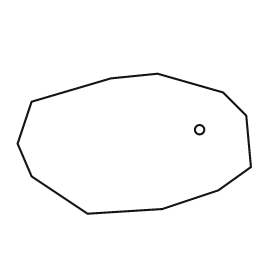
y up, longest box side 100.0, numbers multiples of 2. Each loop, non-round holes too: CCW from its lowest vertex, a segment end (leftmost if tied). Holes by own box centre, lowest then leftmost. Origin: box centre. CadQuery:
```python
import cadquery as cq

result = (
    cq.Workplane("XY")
    .moveTo(-20.0, -30.0)
    .lineTo(12.0, -28.0)
    .lineTo(36.0, -20.0)
    .lineTo(50.0, -10.0)
    .lineTo(48.0, 12.0)
    .lineTo(38.0, 22.0)
    .lineTo(10.0, 30.0)
    .lineTo(-10.0, 28.0)
    .lineTo(-44.0, 18.0)
    .lineTo(-50.0, 0.0)
    .lineTo(-44.0, -14.0)
    .close()
    .moveTo(28.0, 6.0)
    .circle(2.0)
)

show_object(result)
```